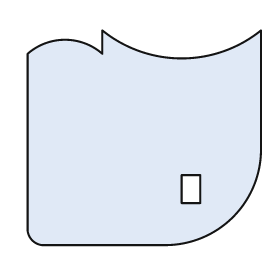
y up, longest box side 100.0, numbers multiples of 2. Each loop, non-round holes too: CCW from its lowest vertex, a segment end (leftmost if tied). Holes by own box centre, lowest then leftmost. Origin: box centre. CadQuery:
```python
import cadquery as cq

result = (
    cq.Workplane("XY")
    .moveTo(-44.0, -46.0)
    .lineTo(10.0, -46.0)
    .threePointArc((38.0, -34.0), (50.0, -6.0))
    .lineTo(50.0, 46.0)
    .threePointArc((16.0, 34.0), (-18.0, 46.0))
    .lineTo(-18.0, 36.0)
    .threePointArc((-34.0, 42.0), (-50.0, 36.0))
    .lineTo(-50.0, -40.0)
    .threePointArc((-48.0, -44.0), (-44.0, -46.0))
    .close()
    .moveTo(16.0, -28.0)
    .lineTo(24.0, -28.0)
    .lineTo(24.0, -16.0)
    .lineTo(16.0, -16.0)
    .close()
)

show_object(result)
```